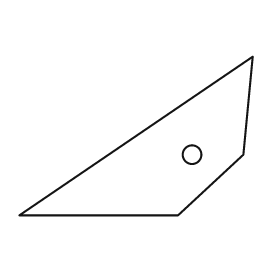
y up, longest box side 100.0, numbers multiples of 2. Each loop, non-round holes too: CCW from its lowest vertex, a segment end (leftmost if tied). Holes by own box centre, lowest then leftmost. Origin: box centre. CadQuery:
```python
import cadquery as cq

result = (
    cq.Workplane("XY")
    .moveTo(-50.0, -34.0)
    .lineTo(18.0, -34.0)
    .lineTo(46.0, -8.0)
    .lineTo(50.0, 34.0)
    .close()
    .moveTo(24.0, -8.0)
    .circle(4.0)
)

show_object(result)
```